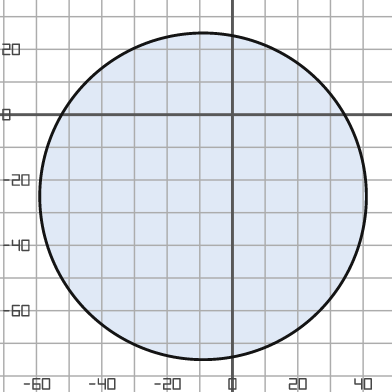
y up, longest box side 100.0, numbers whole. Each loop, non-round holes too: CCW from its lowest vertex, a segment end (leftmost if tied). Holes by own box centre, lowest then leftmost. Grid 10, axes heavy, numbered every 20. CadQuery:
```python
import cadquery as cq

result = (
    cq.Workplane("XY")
    .moveTo(-9.0, -25.0)
    .circle(50.0)
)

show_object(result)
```